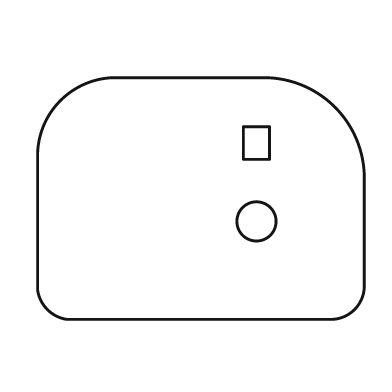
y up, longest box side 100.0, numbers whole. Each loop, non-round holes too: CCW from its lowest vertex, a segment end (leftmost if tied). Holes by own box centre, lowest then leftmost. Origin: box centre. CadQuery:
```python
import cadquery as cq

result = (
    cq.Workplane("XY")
    .moveTo(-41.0, -37.0)
    .lineTo(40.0, -37.0)
    .threePointArc((47.0, -34.0), (50.0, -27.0))
    .lineTo(50.0, 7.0)
    .threePointArc((41.0, 28.0), (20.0, 37.0))
    .lineTo(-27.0, 37.0)
    .threePointArc((-43.0, 30.0), (-50.0, 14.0))
    .lineTo(-50.0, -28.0)
    .threePointArc((-47.0, -34.0), (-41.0, -37.0))
    .close()
    .moveTo(17.0, -7.0)
    .circle(6.0)
    .moveTo(13.0, 12.0)
    .lineTo(21.0, 12.0)
    .lineTo(21.0, 22.0)
    .lineTo(13.0, 22.0)
    .close()
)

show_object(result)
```